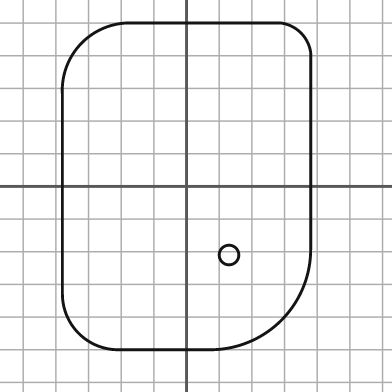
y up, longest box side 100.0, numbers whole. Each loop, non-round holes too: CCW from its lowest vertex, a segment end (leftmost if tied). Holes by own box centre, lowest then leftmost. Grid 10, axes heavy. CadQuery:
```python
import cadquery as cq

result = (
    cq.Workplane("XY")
    .moveTo(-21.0, -50.0)
    .lineTo(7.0, -50.0)
    .threePointArc((29.0, -41.0), (38.0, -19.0))
    .lineTo(38.0, 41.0)
    .threePointArc((35.0, 47.0), (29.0, 50.0))
    .lineTo(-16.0, 50.0)
    .threePointArc((-32.0, 44.0), (-38.0, 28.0))
    .lineTo(-38.0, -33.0)
    .threePointArc((-33.0, -45.0), (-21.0, -50.0))
    .close()
    .moveTo(13.0, -21.0)
    .circle(3.0)
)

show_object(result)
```